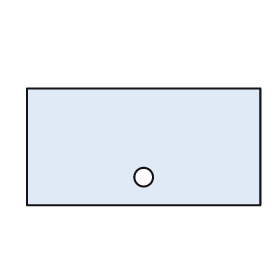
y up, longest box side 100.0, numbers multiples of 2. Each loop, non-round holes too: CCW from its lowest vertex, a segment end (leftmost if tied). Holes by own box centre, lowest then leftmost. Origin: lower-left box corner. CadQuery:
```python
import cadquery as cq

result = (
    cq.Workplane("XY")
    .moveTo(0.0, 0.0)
    .lineTo(100.0, 0.0)
    .lineTo(100.0, 50.0)
    .lineTo(0.0, 50.0)
    .close()
    .moveTo(50.0, 12.0)
    .circle(4.0)
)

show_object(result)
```